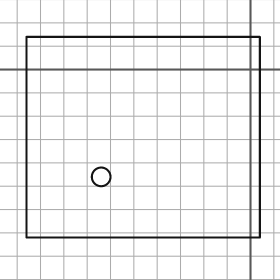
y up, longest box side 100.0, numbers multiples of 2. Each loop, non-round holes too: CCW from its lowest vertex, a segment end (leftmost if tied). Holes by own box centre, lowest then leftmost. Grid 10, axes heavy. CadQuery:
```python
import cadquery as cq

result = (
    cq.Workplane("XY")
    .moveTo(-96.0, -72.0)
    .lineTo(4.0, -72.0)
    .lineTo(4.0, 14.0)
    .lineTo(-96.0, 14.0)
    .close()
    .moveTo(-64.0, -46.0)
    .circle(4.0)
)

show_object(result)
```